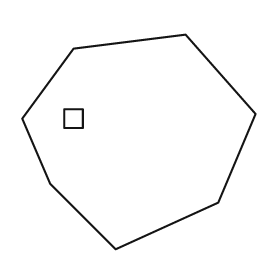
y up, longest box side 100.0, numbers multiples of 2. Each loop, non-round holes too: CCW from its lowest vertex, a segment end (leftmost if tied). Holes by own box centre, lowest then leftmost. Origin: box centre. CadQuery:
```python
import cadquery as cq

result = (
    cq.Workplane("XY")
    .moveTo(-10.0, -46.0)
    .lineTo(34.0, -26.0)
    .lineTo(50.0, 12.0)
    .lineTo(20.0, 46.0)
    .lineTo(-28.0, 40.0)
    .lineTo(-50.0, 10.0)
    .lineTo(-38.0, -18.0)
    .close()
    .moveTo(-32.0, 6.0)
    .lineTo(-24.0, 6.0)
    .lineTo(-24.0, 14.0)
    .lineTo(-32.0, 14.0)
    .close()
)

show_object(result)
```